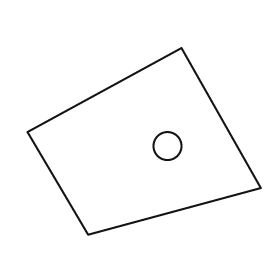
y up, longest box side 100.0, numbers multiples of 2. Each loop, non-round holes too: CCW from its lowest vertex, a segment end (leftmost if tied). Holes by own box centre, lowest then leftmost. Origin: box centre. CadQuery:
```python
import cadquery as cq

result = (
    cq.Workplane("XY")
    .moveTo(-24.0, -40.0)
    .lineTo(50.0, -20.0)
    .lineTo(16.0, 40.0)
    .lineTo(-50.0, 4.0)
    .close()
    .moveTo(10.0, -2.0)
    .circle(6.0)
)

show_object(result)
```